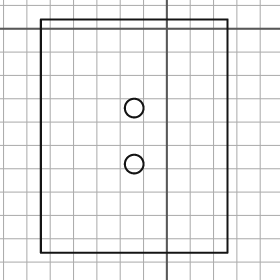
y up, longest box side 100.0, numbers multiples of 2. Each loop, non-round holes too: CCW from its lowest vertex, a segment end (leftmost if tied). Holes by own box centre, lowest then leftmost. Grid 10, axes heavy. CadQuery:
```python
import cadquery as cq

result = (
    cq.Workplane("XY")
    .moveTo(-54.0, -96.0)
    .lineTo(26.0, -96.0)
    .lineTo(26.0, 4.0)
    .lineTo(-54.0, 4.0)
    .close()
    .moveTo(-14.0, -58.0)
    .circle(4.0)
    .moveTo(-14.0, -34.0)
    .circle(4.0)
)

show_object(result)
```